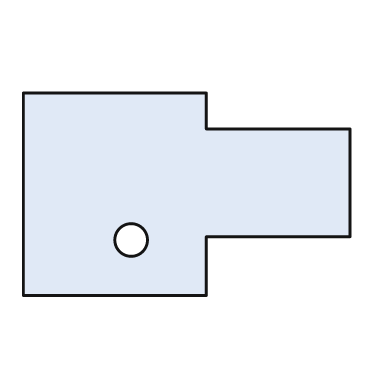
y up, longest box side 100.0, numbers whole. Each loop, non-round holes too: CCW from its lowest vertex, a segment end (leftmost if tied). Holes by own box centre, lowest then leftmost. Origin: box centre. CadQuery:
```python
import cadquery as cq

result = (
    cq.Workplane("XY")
    .moveTo(-50.0, -31.0)
    .lineTo(6.0, -31.0)
    .lineTo(6.0, -13.0)
    .lineTo(50.0, -13.0)
    .lineTo(50.0, 20.0)
    .lineTo(6.0, 20.0)
    .lineTo(6.0, 31.0)
    .lineTo(-50.0, 31.0)
    .close()
    .moveTo(-17.0, -14.0)
    .circle(5.0)
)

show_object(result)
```